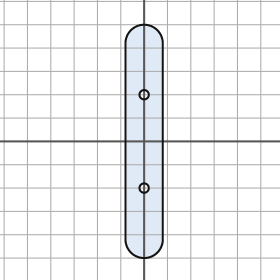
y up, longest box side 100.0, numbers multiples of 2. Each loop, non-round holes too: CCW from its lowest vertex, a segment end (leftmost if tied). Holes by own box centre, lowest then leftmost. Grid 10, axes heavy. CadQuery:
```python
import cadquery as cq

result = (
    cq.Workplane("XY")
    .moveTo(-8.0, -42.0)
    .threePointArc((0.0, -50.0), (8.0, -42.0))
    .lineTo(8.0, 42.0)
    .threePointArc((0.0, 50.0), (-8.0, 42.0))
    .close()
    .moveTo(0.0, -20.0)
    .circle(2.0)
    .moveTo(0.0, 20.0)
    .circle(2.0)
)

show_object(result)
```